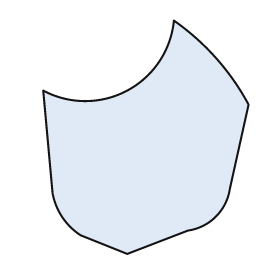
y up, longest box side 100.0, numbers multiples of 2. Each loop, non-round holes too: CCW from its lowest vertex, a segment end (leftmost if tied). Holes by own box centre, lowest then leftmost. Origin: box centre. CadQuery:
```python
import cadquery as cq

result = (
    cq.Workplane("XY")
    .moveTo(-8.0, -50.0)
    .lineTo(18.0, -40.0)
    .threePointArc((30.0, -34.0), (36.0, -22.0))
    .lineTo(44.0, 14.0)
    .threePointArc((30.0, 34.0), (12.0, 50.0))
    .threePointArc((-8.0, 20.0), (-44.0, 20.0))
    .lineTo(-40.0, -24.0)
    .threePointArc((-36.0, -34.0), (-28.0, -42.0))
    .close()
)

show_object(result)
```